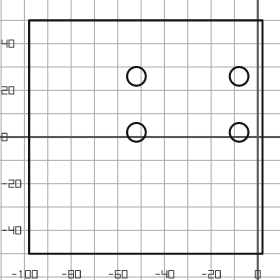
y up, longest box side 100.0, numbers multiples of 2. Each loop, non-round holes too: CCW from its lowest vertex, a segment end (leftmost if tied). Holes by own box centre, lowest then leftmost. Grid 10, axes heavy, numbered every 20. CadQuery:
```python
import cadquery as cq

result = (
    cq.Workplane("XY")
    .moveTo(-98.0, -50.0)
    .lineTo(2.0, -50.0)
    .lineTo(2.0, 50.0)
    .lineTo(-98.0, 50.0)
    .close()
    .moveTo(-52.0, 2.0)
    .circle(4.0)
    .moveTo(-8.0, 2.0)
    .circle(4.0)
    .moveTo(-52.0, 26.0)
    .circle(4.0)
    .moveTo(-8.0, 26.0)
    .circle(4.0)
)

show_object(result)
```